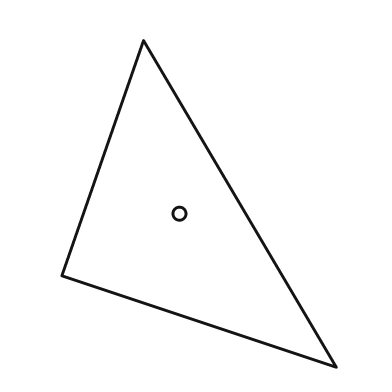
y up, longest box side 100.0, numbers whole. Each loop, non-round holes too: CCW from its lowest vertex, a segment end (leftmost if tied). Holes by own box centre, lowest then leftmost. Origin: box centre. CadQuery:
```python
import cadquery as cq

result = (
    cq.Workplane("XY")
    .moveTo(42.0, -50.0)
    .lineTo(-17.0, 50.0)
    .lineTo(-42.0, -22.0)
    .close()
    .moveTo(-6.0, -3.0)
    .circle(2.0)
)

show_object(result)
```